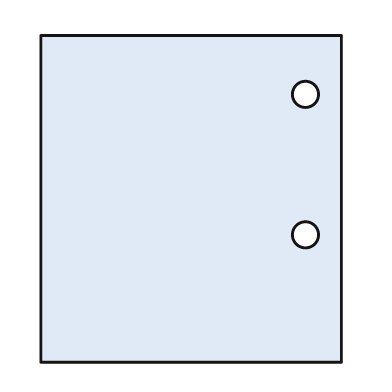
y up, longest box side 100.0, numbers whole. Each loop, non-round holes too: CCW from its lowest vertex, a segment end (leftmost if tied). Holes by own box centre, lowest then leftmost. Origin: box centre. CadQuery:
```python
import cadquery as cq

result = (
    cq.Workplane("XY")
    .moveTo(-46.0, -50.0)
    .lineTo(46.0, -50.0)
    .lineTo(46.0, 50.0)
    .lineTo(-46.0, 50.0)
    .close()
    .moveTo(35.0, -11.0)
    .circle(4.0)
    .moveTo(35.0, 32.0)
    .circle(4.0)
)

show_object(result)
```